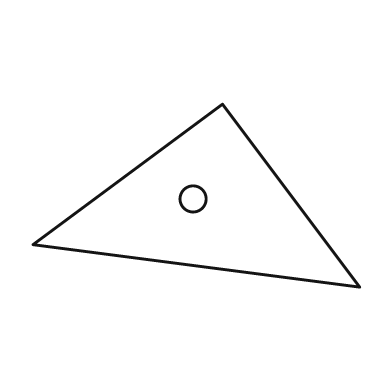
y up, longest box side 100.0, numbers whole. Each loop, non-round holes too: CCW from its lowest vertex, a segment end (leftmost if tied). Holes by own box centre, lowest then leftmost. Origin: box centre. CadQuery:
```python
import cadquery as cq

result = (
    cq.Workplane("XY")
    .moveTo(50.0, -28.0)
    .lineTo(8.0, 28.0)
    .lineTo(-50.0, -15.0)
    .close()
    .moveTo(-1.0, -1.0)
    .circle(4.0)
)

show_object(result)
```